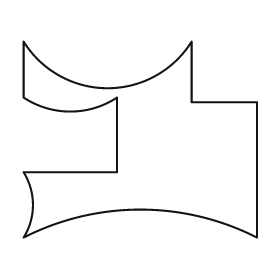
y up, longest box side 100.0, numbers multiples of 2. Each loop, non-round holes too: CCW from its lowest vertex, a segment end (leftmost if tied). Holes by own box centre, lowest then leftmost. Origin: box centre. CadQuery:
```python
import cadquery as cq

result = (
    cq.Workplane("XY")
    .moveTo(-50.0, -42.0)
    .threePointArc((0.0, -30.0), (50.0, -42.0))
    .lineTo(50.0, 16.0)
    .lineTo(22.0, 16.0)
    .lineTo(22.0, 42.0)
    .threePointArc((-14.0, 22.0), (-50.0, 42.0))
    .lineTo(-50.0, 18.0)
    .threePointArc((-30.0, 12.0), (-10.0, 18.0))
    .lineTo(-10.0, -14.0)
    .lineTo(-50.0, -14.0)
    .threePointArc((-46.0, -28.0), (-50.0, -42.0))
    .close()
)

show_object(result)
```